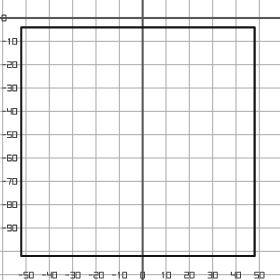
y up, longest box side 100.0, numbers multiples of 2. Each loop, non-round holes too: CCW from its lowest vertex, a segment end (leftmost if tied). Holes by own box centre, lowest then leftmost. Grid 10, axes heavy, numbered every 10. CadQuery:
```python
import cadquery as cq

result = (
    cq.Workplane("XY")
    .moveTo(-52.0, -102.0)
    .lineTo(48.0, -102.0)
    .lineTo(48.0, -4.0)
    .lineTo(-52.0, -4.0)
    .close()
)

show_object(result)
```